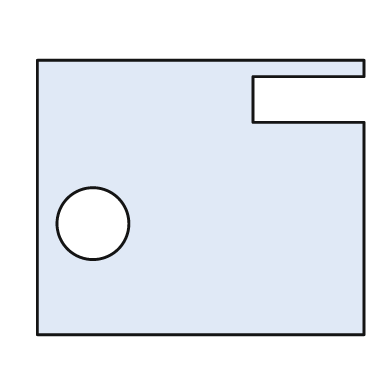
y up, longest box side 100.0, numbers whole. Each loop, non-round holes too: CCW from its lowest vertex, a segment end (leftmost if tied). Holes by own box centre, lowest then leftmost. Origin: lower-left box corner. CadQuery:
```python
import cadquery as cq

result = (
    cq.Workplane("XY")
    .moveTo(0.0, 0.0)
    .lineTo(100.0, 0.0)
    .lineTo(100.0, 65.0)
    .lineTo(66.0, 65.0)
    .lineTo(66.0, 79.0)
    .lineTo(100.0, 79.0)
    .lineTo(100.0, 84.0)
    .lineTo(0.0, 84.0)
    .close()
    .moveTo(17.0, 34.0)
    .circle(11.0)
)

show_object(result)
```